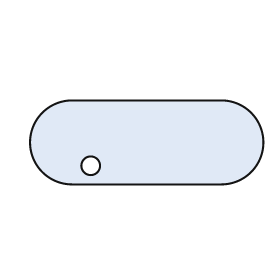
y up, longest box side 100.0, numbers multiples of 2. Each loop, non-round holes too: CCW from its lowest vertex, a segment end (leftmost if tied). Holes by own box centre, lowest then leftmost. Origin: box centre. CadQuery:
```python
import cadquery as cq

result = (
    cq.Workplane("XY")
    .moveTo(-32.0, -18.0)
    .lineTo(32.0, -18.0)
    .threePointArc((50.0, 0.0), (32.0, 18.0))
    .lineTo(-32.0, 18.0)
    .threePointArc((-50.0, 0.0), (-32.0, -18.0))
    .close()
    .moveTo(-24.0, -10.0)
    .circle(4.0)
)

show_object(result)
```